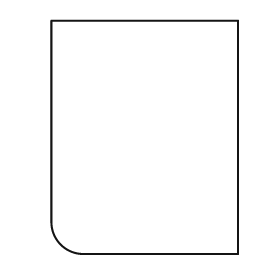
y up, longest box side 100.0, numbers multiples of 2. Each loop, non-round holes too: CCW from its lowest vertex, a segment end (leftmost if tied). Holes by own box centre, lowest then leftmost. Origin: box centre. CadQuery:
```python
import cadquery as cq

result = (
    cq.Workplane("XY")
    .moveTo(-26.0, -50.0)
    .lineTo(40.0, -50.0)
    .lineTo(40.0, 50.0)
    .lineTo(-40.0, 50.0)
    .lineTo(-40.0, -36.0)
    .threePointArc((-36.0, -46.0), (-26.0, -50.0))
    .close()
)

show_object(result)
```